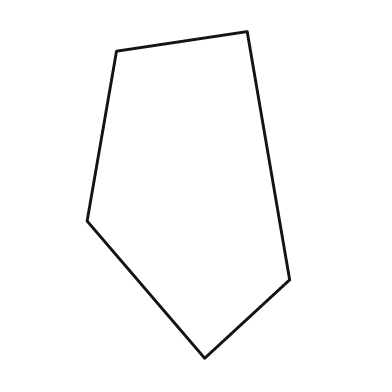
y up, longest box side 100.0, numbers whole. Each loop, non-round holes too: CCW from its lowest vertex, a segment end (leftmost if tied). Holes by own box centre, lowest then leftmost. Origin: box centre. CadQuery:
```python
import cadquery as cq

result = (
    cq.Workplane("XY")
    .moveTo(5.0, -50.0)
    .lineTo(31.0, -26.0)
    .lineTo(18.0, 50.0)
    .lineTo(-22.0, 44.0)
    .lineTo(-31.0, -8.0)
    .close()
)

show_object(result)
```